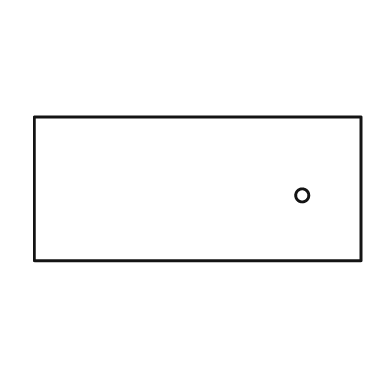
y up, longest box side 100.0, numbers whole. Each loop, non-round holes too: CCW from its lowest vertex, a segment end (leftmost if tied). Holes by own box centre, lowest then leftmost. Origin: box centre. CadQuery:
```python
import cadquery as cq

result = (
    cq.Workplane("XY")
    .moveTo(-50.0, -22.0)
    .lineTo(50.0, -22.0)
    .lineTo(50.0, 22.0)
    .lineTo(-50.0, 22.0)
    .close()
    .moveTo(32.0, -2.0)
    .circle(2.0)
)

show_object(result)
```